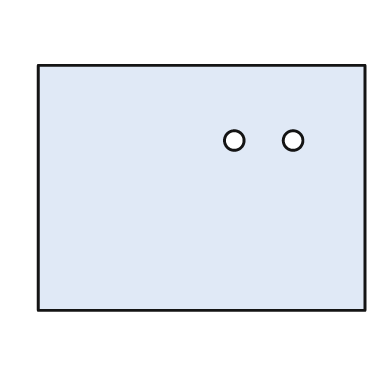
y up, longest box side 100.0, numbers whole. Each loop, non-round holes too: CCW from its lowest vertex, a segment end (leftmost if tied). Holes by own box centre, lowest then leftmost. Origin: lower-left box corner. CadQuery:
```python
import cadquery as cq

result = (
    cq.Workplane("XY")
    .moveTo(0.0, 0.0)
    .lineTo(100.0, 0.0)
    .lineTo(100.0, 75.0)
    .lineTo(0.0, 75.0)
    .close()
    .moveTo(60.0, 52.0)
    .circle(3.0)
    .moveTo(78.0, 52.0)
    .circle(3.0)
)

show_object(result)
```